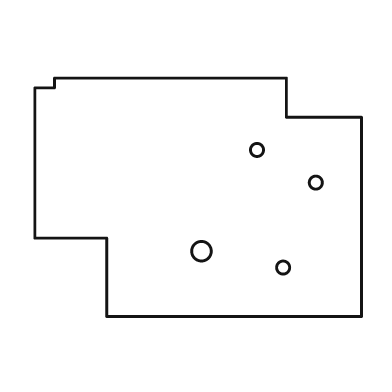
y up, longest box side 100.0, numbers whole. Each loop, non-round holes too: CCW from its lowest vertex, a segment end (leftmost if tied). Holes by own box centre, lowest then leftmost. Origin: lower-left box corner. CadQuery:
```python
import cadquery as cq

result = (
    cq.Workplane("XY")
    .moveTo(22.0, 0.0)
    .lineTo(100.0, 0.0)
    .lineTo(100.0, 61.0)
    .lineTo(77.0, 61.0)
    .lineTo(77.0, 73.0)
    .lineTo(6.0, 73.0)
    .lineTo(6.0, 70.0)
    .lineTo(0.0, 70.0)
    .lineTo(0.0, 24.0)
    .lineTo(22.0, 24.0)
    .close()
    .moveTo(76.0, 15.0)
    .circle(2.0)
    .moveTo(51.0, 20.0)
    .circle(3.0)
    .moveTo(86.0, 41.0)
    .circle(2.0)
    .moveTo(68.0, 51.0)
    .circle(2.0)
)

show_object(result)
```